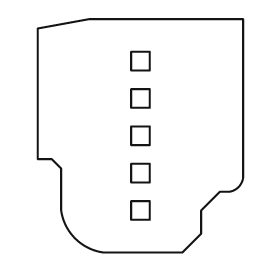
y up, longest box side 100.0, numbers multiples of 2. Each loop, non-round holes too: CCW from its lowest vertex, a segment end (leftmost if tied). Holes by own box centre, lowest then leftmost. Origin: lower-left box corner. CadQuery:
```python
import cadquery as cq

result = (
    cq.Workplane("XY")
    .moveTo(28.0, 0.0)
    .lineTo(62.0, 0.0)
    .lineTo(70.0, 8.0)
    .lineTo(70.0, 18.0)
    .lineTo(78.0, 26.0)
    .lineTo(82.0, 26.0)
    .threePointArc((86.0, 28.0), (88.0, 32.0))
    .lineTo(88.0, 100.0)
    .lineTo(22.0, 100.0)
    .lineTo(0.0, 96.0)
    .lineTo(0.0, 40.0)
    .lineTo(6.0, 40.0)
    .lineTo(10.0, 36.0)
    .lineTo(10.0, 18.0)
    .threePointArc((16.0, 6.0), (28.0, 0.0))
    .close()
    .moveTo(40.0, 14.0)
    .lineTo(48.0, 14.0)
    .lineTo(48.0, 22.0)
    .lineTo(40.0, 22.0)
    .close()
    .moveTo(40.0, 30.0)
    .lineTo(48.0, 30.0)
    .lineTo(48.0, 38.0)
    .lineTo(40.0, 38.0)
    .close()
    .moveTo(40.0, 46.0)
    .lineTo(48.0, 46.0)
    .lineTo(48.0, 54.0)
    .lineTo(40.0, 54.0)
    .close()
    .moveTo(40.0, 62.0)
    .lineTo(48.0, 62.0)
    .lineTo(48.0, 70.0)
    .lineTo(40.0, 70.0)
    .close()
    .moveTo(40.0, 78.0)
    .lineTo(48.0, 78.0)
    .lineTo(48.0, 86.0)
    .lineTo(40.0, 86.0)
    .close()
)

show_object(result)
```